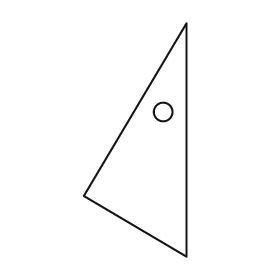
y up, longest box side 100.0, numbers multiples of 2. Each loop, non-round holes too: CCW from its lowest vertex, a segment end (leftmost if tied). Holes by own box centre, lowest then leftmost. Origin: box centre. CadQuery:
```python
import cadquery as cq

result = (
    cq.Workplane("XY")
    .moveTo(22.0, -50.0)
    .lineTo(22.0, 50.0)
    .lineTo(-22.0, -24.0)
    .close()
    .moveTo(12.0, 12.0)
    .circle(4.0)
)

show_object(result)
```